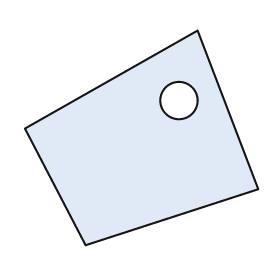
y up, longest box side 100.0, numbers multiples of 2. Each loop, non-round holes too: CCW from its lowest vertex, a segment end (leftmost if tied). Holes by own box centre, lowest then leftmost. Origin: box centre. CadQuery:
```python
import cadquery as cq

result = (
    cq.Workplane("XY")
    .moveTo(-24.0, -46.0)
    .lineTo(50.0, -22.0)
    .lineTo(24.0, 46.0)
    .lineTo(-50.0, 4.0)
    .close()
    .moveTo(16.0, 16.0)
    .circle(8.0)
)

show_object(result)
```